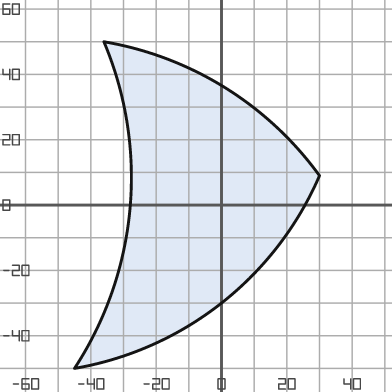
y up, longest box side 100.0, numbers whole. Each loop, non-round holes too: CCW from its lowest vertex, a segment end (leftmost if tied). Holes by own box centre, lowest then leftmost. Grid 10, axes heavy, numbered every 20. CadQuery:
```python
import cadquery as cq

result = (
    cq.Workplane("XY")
    .moveTo(-45.0, -50.0)
    .threePointArc((0.0, -30.0), (30.0, 9.0))
    .threePointArc((1.0, 36.0), (-36.0, 50.0))
    .threePointArc((-28.0, -1.0), (-45.0, -50.0))
    .close()
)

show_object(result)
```